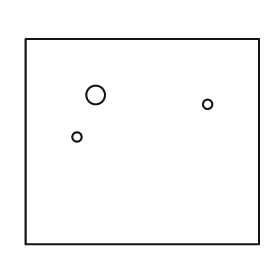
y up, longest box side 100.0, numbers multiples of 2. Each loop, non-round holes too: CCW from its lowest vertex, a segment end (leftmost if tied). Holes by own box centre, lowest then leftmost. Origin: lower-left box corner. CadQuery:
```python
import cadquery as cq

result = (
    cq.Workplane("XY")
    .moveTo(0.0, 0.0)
    .lineTo(100.0, 0.0)
    .lineTo(100.0, 88.0)
    .lineTo(0.0, 88.0)
    .close()
    .moveTo(22.0, 46.0)
    .circle(2.0)
    .moveTo(78.0, 60.0)
    .circle(2.0)
    .moveTo(30.0, 64.0)
    .circle(4.0)
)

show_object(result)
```